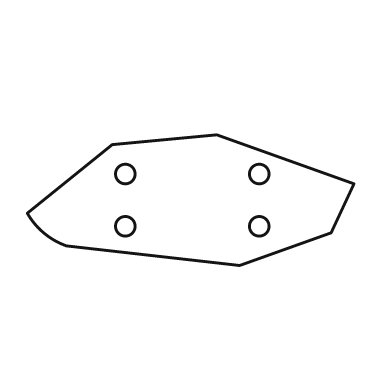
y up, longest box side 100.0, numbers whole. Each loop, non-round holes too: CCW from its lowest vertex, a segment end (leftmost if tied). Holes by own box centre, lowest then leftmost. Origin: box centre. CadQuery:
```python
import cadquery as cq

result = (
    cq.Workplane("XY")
    .moveTo(15.0, -20.0)
    .lineTo(43.0, -10.0)
    .lineTo(50.0, 5.0)
    .lineTo(8.0, 20.0)
    .lineTo(-24.0, 17.0)
    .lineTo(-50.0, -4.0)
    .threePointArc((-45.0, -10.0), (-38.0, -14.0))
    .close()
    .moveTo(-20.0, -8.0)
    .circle(3.0)
    .moveTo(21.0, -8.0)
    .circle(3.0)
    .moveTo(-20.0, 8.0)
    .circle(3.0)
    .moveTo(21.0, 8.0)
    .circle(3.0)
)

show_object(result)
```